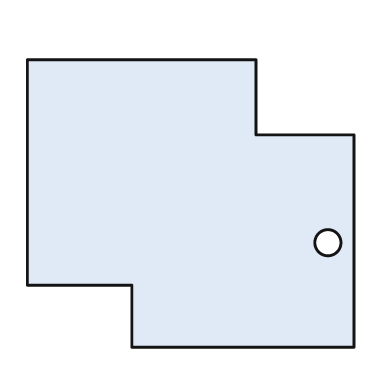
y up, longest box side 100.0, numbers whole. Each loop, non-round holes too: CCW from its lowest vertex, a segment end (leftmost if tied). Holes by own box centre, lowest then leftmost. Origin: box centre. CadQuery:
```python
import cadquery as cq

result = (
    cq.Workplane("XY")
    .moveTo(-18.0, -44.0)
    .lineTo(50.0, -44.0)
    .lineTo(50.0, 21.0)
    .lineTo(20.0, 21.0)
    .lineTo(20.0, 44.0)
    .lineTo(-50.0, 44.0)
    .lineTo(-50.0, -25.0)
    .lineTo(-18.0, -25.0)
    .close()
    .moveTo(42.0, -12.0)
    .circle(4.0)
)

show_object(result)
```